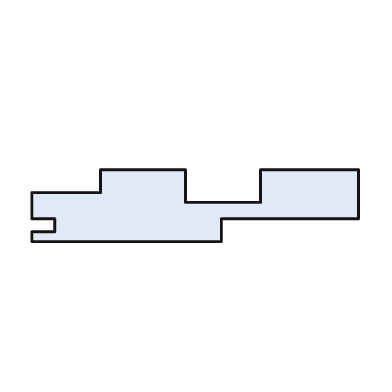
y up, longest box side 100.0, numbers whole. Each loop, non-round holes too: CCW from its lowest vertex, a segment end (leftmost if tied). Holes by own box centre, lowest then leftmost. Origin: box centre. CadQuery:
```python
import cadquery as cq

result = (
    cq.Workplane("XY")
    .moveTo(-50.0, -11.0)
    .lineTo(8.0, -11.0)
    .lineTo(8.0, -4.0)
    .lineTo(50.0, -4.0)
    .lineTo(50.0, 11.0)
    .lineTo(20.0, 11.0)
    .lineTo(20.0, 1.0)
    .lineTo(-3.0, 1.0)
    .lineTo(-3.0, 11.0)
    .lineTo(-29.0, 11.0)
    .lineTo(-29.0, 4.0)
    .lineTo(-50.0, 4.0)
    .lineTo(-50.0, -4.0)
    .lineTo(-43.0, -4.0)
    .lineTo(-43.0, -8.0)
    .lineTo(-50.0, -8.0)
    .close()
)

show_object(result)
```